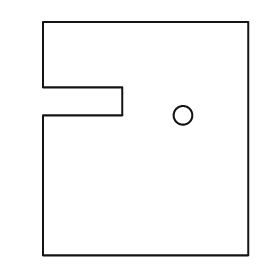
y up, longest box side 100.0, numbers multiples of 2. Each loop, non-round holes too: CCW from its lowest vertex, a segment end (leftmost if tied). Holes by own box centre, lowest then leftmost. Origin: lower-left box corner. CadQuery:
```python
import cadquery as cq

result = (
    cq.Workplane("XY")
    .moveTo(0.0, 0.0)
    .lineTo(88.0, 0.0)
    .lineTo(88.0, 100.0)
    .lineTo(0.0, 100.0)
    .lineTo(0.0, 72.0)
    .lineTo(34.0, 72.0)
    .lineTo(34.0, 60.0)
    .lineTo(0.0, 60.0)
    .close()
    .moveTo(60.0, 60.0)
    .circle(4.0)
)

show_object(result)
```